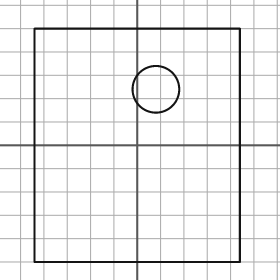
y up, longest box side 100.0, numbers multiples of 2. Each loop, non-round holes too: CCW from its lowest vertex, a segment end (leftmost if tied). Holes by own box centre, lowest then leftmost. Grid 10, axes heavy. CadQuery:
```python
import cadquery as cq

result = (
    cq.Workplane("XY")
    .moveTo(-44.0, -50.0)
    .lineTo(44.0, -50.0)
    .lineTo(44.0, 50.0)
    .lineTo(-44.0, 50.0)
    .close()
    .moveTo(8.0, 24.0)
    .circle(10.0)
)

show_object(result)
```